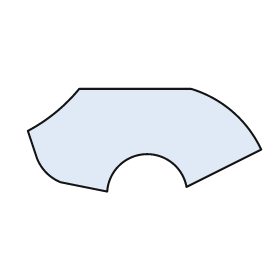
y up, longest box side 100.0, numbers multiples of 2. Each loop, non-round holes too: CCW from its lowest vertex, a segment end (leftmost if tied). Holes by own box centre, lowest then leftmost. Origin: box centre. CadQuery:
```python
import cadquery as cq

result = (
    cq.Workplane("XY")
    .moveTo(-16.0, -22.0)
    .threePointArc((0.0, -6.0), (18.0, -20.0))
    .lineTo(50.0, -4.0)
    .threePointArc((38.0, 12.0), (20.0, 22.0))
    .lineTo(-28.0, 22.0)
    .threePointArc((-38.0, 12.0), (-50.0, 4.0))
    .lineTo(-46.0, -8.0)
    .threePointArc((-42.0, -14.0), (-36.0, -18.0))
    .close()
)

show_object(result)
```